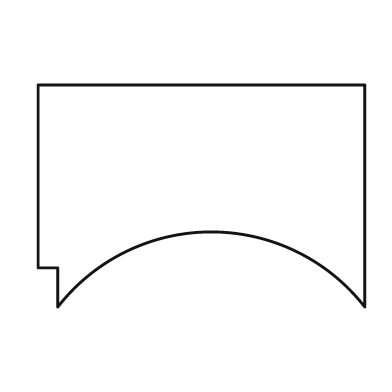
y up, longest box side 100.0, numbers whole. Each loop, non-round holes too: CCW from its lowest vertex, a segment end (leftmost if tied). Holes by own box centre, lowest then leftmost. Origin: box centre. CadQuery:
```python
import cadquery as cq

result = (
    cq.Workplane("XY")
    .moveTo(-44.0, -34.0)
    .threePointArc((3.0, -11.0), (50.0, -34.0))
    .lineTo(50.0, 34.0)
    .lineTo(-50.0, 34.0)
    .lineTo(-50.0, -22.0)
    .lineTo(-44.0, -22.0)
    .close()
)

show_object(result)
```